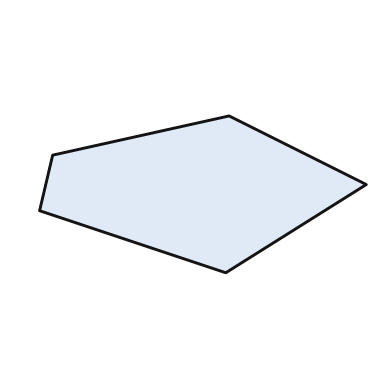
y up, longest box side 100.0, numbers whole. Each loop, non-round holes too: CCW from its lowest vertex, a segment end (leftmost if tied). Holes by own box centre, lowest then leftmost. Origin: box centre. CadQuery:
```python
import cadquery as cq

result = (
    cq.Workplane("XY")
    .moveTo(7.0, -24.0)
    .lineTo(50.0, 3.0)
    .lineTo(8.0, 24.0)
    .lineTo(-46.0, 12.0)
    .lineTo(-50.0, -5.0)
    .close()
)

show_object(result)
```